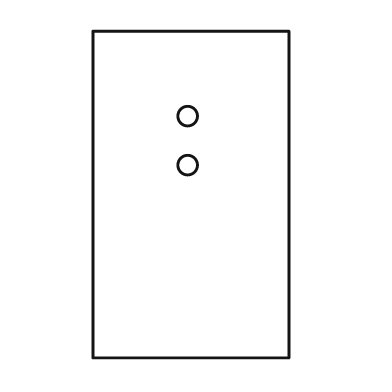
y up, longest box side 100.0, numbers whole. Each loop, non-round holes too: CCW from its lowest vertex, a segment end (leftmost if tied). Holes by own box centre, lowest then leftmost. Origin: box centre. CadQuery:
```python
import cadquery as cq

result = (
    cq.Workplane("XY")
    .moveTo(-30.0, -50.0)
    .lineTo(30.0, -50.0)
    .lineTo(30.0, 50.0)
    .lineTo(-30.0, 50.0)
    .close()
    .moveTo(-1.0, 9.0)
    .circle(3.0)
    .moveTo(-1.0, 24.0)
    .circle(3.0)
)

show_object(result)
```